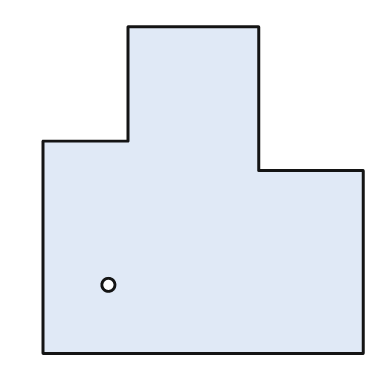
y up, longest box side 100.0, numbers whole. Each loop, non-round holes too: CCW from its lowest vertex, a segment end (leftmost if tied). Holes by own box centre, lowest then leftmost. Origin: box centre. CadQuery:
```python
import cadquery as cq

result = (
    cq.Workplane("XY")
    .moveTo(-49.0, -50.0)
    .lineTo(49.0, -50.0)
    .lineTo(49.0, 6.0)
    .lineTo(17.0, 6.0)
    .lineTo(17.0, 50.0)
    .lineTo(-23.0, 50.0)
    .lineTo(-23.0, 15.0)
    .lineTo(-49.0, 15.0)
    .close()
    .moveTo(-29.0, -29.0)
    .circle(2.0)
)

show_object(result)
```